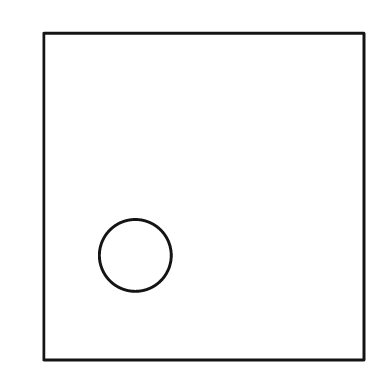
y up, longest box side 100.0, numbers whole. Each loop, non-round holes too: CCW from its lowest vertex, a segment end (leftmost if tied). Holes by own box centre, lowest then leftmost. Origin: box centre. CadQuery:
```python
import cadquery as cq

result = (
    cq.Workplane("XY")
    .moveTo(-49.0, -50.0)
    .lineTo(49.0, -50.0)
    .lineTo(49.0, 50.0)
    .lineTo(-49.0, 50.0)
    .close()
    .moveTo(-21.0, -18.0)
    .circle(11.0)
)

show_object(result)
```